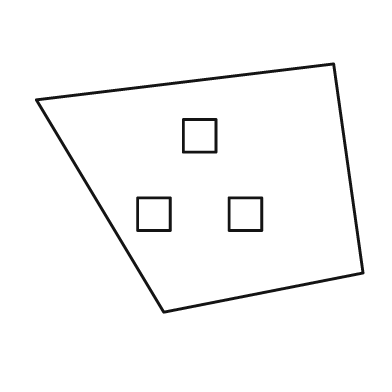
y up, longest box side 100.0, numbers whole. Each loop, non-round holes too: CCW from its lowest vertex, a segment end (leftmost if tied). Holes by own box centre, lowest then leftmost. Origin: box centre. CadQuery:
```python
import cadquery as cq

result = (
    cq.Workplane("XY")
    .moveTo(-11.0, -38.0)
    .lineTo(50.0, -26.0)
    .lineTo(41.0, 38.0)
    .lineTo(-50.0, 27.0)
    .close()
    .moveTo(-19.0, -13.0)
    .lineTo(-9.0, -13.0)
    .lineTo(-9.0, -3.0)
    .lineTo(-19.0, -3.0)
    .close()
    .moveTo(9.0, -13.0)
    .lineTo(19.0, -13.0)
    .lineTo(19.0, -3.0)
    .lineTo(9.0, -3.0)
    .close()
    .moveTo(-5.0, 11.0)
    .lineTo(5.0, 11.0)
    .lineTo(5.0, 21.0)
    .lineTo(-5.0, 21.0)
    .close()
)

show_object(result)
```